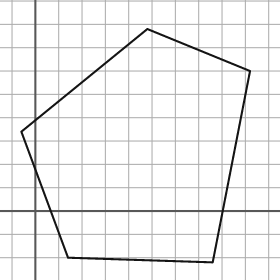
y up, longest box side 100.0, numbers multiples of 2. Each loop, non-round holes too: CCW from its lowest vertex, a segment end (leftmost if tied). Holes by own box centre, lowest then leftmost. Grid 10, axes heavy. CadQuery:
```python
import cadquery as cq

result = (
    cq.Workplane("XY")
    .moveTo(76.0, -22.0)
    .lineTo(92.0, 60.0)
    .lineTo(48.0, 78.0)
    .lineTo(-6.0, 34.0)
    .lineTo(14.0, -20.0)
    .close()
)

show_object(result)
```